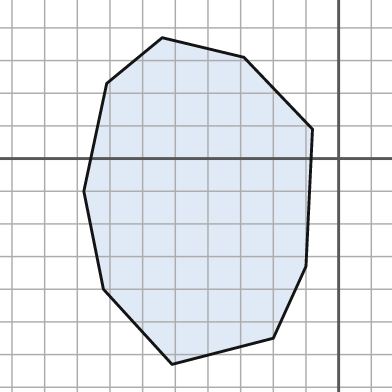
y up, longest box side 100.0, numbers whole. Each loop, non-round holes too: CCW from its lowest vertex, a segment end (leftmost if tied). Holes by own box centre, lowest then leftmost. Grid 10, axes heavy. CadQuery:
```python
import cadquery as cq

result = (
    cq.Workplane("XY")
    .moveTo(-51.0, -63.0)
    .lineTo(-20.0, -55.0)
    .lineTo(-10.0, -33.0)
    .lineTo(-8.0, 9.0)
    .lineTo(-29.0, 31.0)
    .lineTo(-54.0, 37.0)
    .lineTo(-71.0, 23.0)
    .lineTo(-78.0, -10.0)
    .lineTo(-72.0, -40.0)
    .close()
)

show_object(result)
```